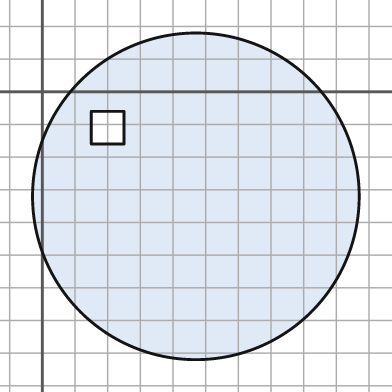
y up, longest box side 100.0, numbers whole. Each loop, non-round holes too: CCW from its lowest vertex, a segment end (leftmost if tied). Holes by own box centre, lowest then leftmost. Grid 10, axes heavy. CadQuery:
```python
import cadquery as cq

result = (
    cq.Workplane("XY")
    .moveTo(47.0, -32.0)
    .circle(50.0)
    .moveTo(15.0, -16.0)
    .lineTo(25.0, -16.0)
    .lineTo(25.0, -6.0)
    .lineTo(15.0, -6.0)
    .close()
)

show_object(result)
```